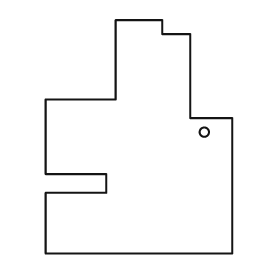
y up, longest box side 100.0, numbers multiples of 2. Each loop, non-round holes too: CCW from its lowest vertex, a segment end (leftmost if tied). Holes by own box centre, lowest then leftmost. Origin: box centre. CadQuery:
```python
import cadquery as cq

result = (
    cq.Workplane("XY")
    .moveTo(-40.0, -50.0)
    .lineTo(40.0, -50.0)
    .lineTo(40.0, 8.0)
    .lineTo(22.0, 8.0)
    .lineTo(22.0, 44.0)
    .lineTo(10.0, 44.0)
    .lineTo(10.0, 50.0)
    .lineTo(-10.0, 50.0)
    .lineTo(-10.0, 16.0)
    .lineTo(-40.0, 16.0)
    .lineTo(-40.0, -16.0)
    .lineTo(-14.0, -16.0)
    .lineTo(-14.0, -24.0)
    .lineTo(-40.0, -24.0)
    .close()
    .moveTo(28.0, 2.0)
    .circle(2.0)
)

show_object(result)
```